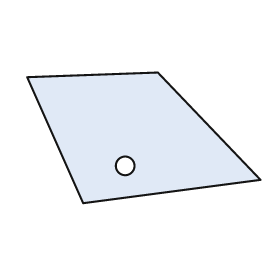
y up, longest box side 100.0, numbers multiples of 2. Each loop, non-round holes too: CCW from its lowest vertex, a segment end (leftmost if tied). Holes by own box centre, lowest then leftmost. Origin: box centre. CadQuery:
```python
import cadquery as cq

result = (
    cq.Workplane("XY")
    .moveTo(-26.0, -28.0)
    .lineTo(50.0, -18.0)
    .lineTo(6.0, 28.0)
    .lineTo(-50.0, 26.0)
    .close()
    .moveTo(-8.0, -12.0)
    .circle(4.0)
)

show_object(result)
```